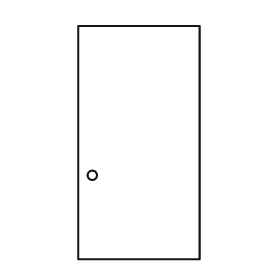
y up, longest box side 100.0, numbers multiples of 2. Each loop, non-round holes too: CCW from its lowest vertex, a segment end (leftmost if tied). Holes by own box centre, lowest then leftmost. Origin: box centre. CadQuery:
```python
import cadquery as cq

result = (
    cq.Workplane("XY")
    .moveTo(-26.0, -50.0)
    .lineTo(26.0, -50.0)
    .lineTo(26.0, 50.0)
    .lineTo(-26.0, 50.0)
    .close()
    .moveTo(-20.0, -14.0)
    .circle(2.0)
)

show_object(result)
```